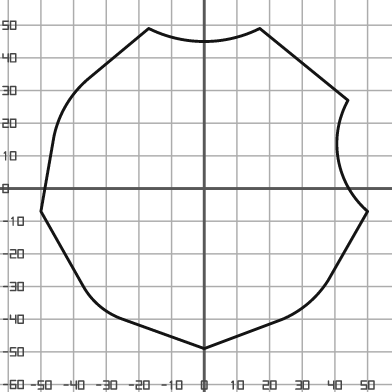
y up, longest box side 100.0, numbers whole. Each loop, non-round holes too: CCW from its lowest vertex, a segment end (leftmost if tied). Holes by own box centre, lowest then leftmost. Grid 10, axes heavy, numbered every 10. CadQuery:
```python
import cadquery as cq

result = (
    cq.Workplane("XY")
    .moveTo(0.0, -49.0)
    .lineTo(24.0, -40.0)
    .threePointArc((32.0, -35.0), (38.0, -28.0))
    .lineTo(50.0, -7.0)
    .threePointArc((41.0, 9.0), (44.0, 27.0))
    .lineTo(17.0, 49.0)
    .threePointArc((0.0, 45.0), (-17.0, 49.0))
    .lineTo(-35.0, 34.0)
    .threePointArc((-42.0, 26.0), (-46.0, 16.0))
    .lineTo(-50.0, -7.0)
    .lineTo(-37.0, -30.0)
    .threePointArc((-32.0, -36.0), (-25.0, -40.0))
    .close()
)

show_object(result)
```